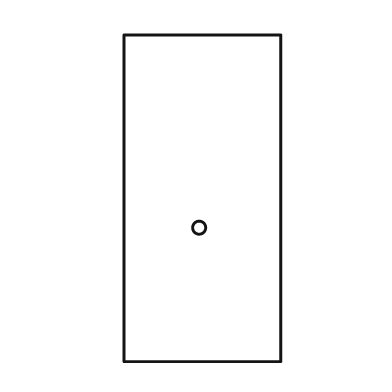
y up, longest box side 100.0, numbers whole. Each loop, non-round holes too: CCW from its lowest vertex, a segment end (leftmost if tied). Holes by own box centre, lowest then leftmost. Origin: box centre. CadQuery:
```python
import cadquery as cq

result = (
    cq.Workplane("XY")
    .moveTo(-24.0, -50.0)
    .lineTo(24.0, -50.0)
    .lineTo(24.0, 50.0)
    .lineTo(-24.0, 50.0)
    .close()
    .moveTo(-1.0, -9.0)
    .circle(2.0)
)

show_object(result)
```